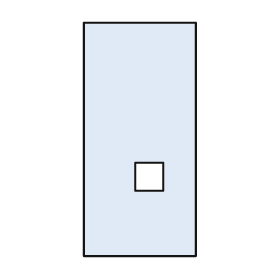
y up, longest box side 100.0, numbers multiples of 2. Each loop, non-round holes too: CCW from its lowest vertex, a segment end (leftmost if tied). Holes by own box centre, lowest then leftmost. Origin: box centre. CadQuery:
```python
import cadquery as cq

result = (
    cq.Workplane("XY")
    .moveTo(-24.0, -50.0)
    .lineTo(24.0, -50.0)
    .lineTo(24.0, 50.0)
    .lineTo(-24.0, 50.0)
    .close()
    .moveTo(-2.0, -22.0)
    .lineTo(10.0, -22.0)
    .lineTo(10.0, -10.0)
    .lineTo(-2.0, -10.0)
    .close()
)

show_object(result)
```